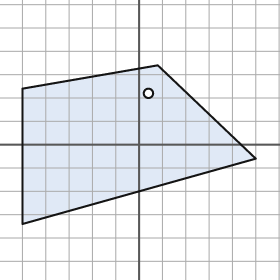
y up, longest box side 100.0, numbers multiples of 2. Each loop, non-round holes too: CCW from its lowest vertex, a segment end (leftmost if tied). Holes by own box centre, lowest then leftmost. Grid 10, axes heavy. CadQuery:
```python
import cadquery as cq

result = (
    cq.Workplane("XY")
    .moveTo(-50.0, -34.0)
    .lineTo(50.0, -6.0)
    .lineTo(8.0, 34.0)
    .lineTo(-50.0, 24.0)
    .close()
    .moveTo(4.0, 22.0)
    .circle(2.0)
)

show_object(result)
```